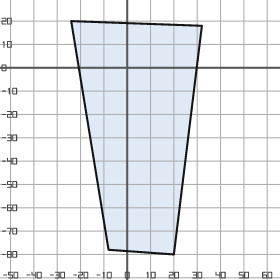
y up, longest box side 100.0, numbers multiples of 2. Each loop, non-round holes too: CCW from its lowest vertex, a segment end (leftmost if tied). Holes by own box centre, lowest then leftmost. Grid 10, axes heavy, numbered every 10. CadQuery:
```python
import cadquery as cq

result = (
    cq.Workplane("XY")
    .moveTo(20.0, -80.0)
    .lineTo(32.0, 18.0)
    .lineTo(-24.0, 20.0)
    .lineTo(-8.0, -78.0)
    .close()
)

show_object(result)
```